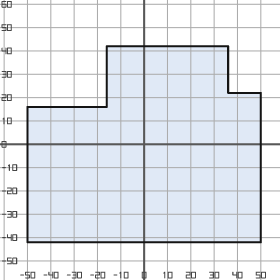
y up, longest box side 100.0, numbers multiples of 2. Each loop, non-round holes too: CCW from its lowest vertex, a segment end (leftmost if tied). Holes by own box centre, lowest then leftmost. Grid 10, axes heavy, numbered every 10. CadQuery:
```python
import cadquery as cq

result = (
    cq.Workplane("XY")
    .moveTo(-50.0, -42.0)
    .lineTo(50.0, -42.0)
    .lineTo(50.0, 22.0)
    .lineTo(36.0, 22.0)
    .lineTo(36.0, 42.0)
    .lineTo(-16.0, 42.0)
    .lineTo(-16.0, 16.0)
    .lineTo(-50.0, 16.0)
    .close()
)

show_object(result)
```